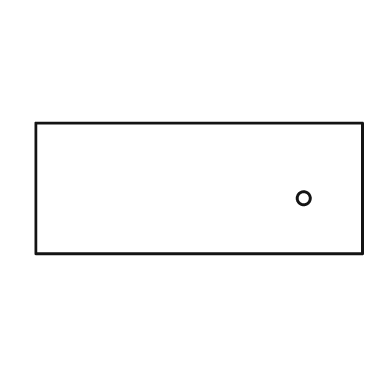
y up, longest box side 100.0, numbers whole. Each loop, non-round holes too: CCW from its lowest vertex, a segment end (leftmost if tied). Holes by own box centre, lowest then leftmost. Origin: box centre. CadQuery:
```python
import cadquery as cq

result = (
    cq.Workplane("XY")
    .moveTo(-50.0, -20.0)
    .lineTo(50.0, -20.0)
    .lineTo(50.0, 20.0)
    .lineTo(-50.0, 20.0)
    .close()
    .moveTo(32.0, -3.0)
    .circle(2.0)
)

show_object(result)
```